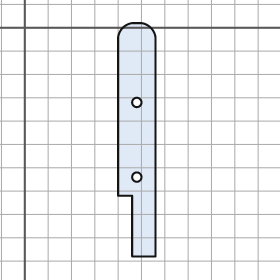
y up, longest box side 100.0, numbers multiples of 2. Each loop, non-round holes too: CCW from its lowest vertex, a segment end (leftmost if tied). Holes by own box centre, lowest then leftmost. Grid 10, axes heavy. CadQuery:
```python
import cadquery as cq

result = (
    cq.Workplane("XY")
    .moveTo(46.0, -98.0)
    .lineTo(56.0, -98.0)
    .lineTo(56.0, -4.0)
    .threePointArc((54.0, 0.0), (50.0, 2.0))
    .lineTo(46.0, 2.0)
    .threePointArc((42.0, 0.0), (40.0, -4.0))
    .lineTo(40.0, -72.0)
    .lineTo(46.0, -72.0)
    .close()
    .moveTo(48.0, -64.0)
    .circle(2.0)
    .moveTo(48.0, -32.0)
    .circle(2.0)
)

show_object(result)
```